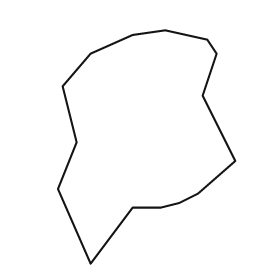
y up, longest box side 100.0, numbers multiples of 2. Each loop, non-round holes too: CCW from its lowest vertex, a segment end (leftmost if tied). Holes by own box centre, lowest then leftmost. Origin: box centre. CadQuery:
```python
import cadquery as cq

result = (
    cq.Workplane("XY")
    .moveTo(-24.0, -50.0)
    .lineTo(-6.0, -26.0)
    .lineTo(6.0, -26.0)
    .lineTo(14.0, -24.0)
    .lineTo(22.0, -20.0)
    .lineTo(38.0, -6.0)
    .lineTo(24.0, 22.0)
    .lineTo(30.0, 40.0)
    .lineTo(26.0, 46.0)
    .lineTo(8.0, 50.0)
    .lineTo(-6.0, 48.0)
    .lineTo(-24.0, 40.0)
    .lineTo(-36.0, 26.0)
    .lineTo(-30.0, 2.0)
    .lineTo(-38.0, -18.0)
    .close()
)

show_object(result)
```